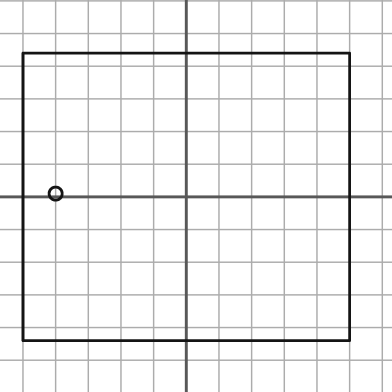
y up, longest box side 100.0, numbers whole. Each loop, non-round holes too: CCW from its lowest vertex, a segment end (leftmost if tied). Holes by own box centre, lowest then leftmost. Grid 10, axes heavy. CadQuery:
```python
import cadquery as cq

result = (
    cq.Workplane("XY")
    .moveTo(-50.0, -44.0)
    .lineTo(50.0, -44.0)
    .lineTo(50.0, 44.0)
    .lineTo(-50.0, 44.0)
    .close()
    .moveTo(-40.0, 1.0)
    .circle(2.0)
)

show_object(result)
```